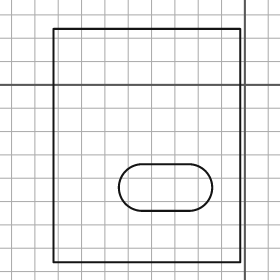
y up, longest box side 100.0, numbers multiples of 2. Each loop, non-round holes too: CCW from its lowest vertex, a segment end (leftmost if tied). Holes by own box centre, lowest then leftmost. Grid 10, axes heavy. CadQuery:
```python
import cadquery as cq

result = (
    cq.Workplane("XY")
    .moveTo(-82.0, -76.0)
    .lineTo(-2.0, -76.0)
    .lineTo(-2.0, 24.0)
    .lineTo(-82.0, 24.0)
    .close()
    .moveTo(-44.0, -54.0)
    .lineTo(-24.0, -54.0)
    .threePointArc((-14.0, -44.0), (-24.0, -34.0))
    .lineTo(-44.0, -34.0)
    .threePointArc((-54.0, -44.0), (-44.0, -54.0))
    .close()
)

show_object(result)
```